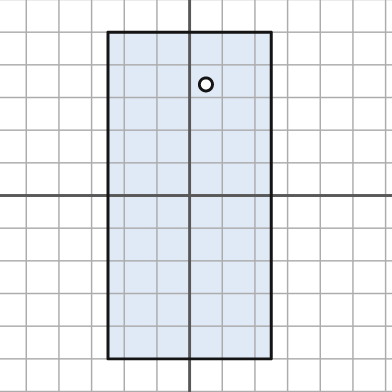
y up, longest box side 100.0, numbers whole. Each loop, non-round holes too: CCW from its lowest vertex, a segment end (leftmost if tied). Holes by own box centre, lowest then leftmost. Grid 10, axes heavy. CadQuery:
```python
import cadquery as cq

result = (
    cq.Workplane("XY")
    .moveTo(-25.0, -50.0)
    .lineTo(25.0, -50.0)
    .lineTo(25.0, 50.0)
    .lineTo(-25.0, 50.0)
    .close()
    .moveTo(5.0, 34.0)
    .circle(2.0)
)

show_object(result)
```